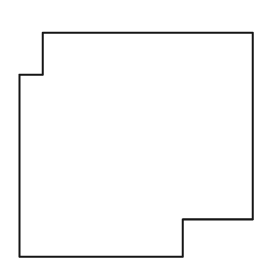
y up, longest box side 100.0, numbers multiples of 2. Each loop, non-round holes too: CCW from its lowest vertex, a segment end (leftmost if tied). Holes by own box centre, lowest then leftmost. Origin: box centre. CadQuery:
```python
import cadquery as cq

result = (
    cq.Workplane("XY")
    .moveTo(-50.0, -48.0)
    .lineTo(20.0, -48.0)
    .lineTo(20.0, -32.0)
    .lineTo(50.0, -32.0)
    .lineTo(50.0, 48.0)
    .lineTo(-40.0, 48.0)
    .lineTo(-40.0, 30.0)
    .lineTo(-50.0, 30.0)
    .close()
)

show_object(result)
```